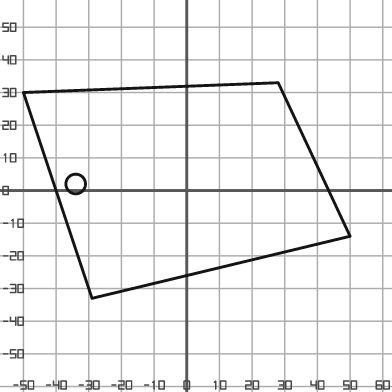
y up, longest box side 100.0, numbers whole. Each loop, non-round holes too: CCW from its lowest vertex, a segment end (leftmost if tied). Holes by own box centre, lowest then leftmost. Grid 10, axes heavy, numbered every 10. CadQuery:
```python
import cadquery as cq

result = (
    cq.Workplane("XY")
    .moveTo(-29.0, -33.0)
    .lineTo(50.0, -14.0)
    .lineTo(28.0, 33.0)
    .lineTo(-50.0, 30.0)
    .close()
    .moveTo(-34.0, 2.0)
    .circle(3.0)
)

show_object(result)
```